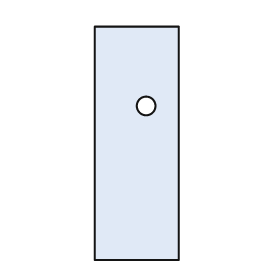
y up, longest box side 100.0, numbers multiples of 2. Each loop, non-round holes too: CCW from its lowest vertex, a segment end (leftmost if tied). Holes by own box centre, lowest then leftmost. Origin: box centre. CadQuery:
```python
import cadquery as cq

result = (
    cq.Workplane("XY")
    .moveTo(-18.0, -50.0)
    .lineTo(18.0, -50.0)
    .lineTo(18.0, 50.0)
    .lineTo(-18.0, 50.0)
    .close()
    .moveTo(4.0, 16.0)
    .circle(4.0)
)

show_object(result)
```